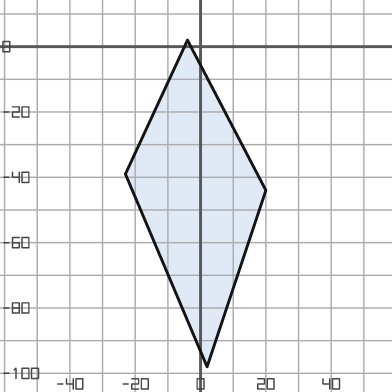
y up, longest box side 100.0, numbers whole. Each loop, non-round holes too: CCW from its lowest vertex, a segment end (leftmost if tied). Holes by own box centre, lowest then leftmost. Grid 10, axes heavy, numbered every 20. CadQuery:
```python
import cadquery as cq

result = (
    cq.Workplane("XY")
    .moveTo(2.0, -98.0)
    .lineTo(20.0, -44.0)
    .lineTo(-4.0, 2.0)
    .lineTo(-23.0, -39.0)
    .close()
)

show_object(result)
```